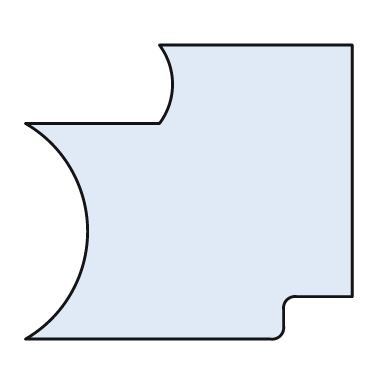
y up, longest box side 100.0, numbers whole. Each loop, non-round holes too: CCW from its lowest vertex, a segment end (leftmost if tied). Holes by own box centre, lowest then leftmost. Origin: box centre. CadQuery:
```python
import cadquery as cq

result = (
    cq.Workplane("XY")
    .moveTo(-50.0, -45.0)
    .lineTo(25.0, -45.0)
    .threePointArc((28.0, -44.0), (29.0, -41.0))
    .lineTo(29.0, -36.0)
    .threePointArc((30.0, -33.0), (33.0, -32.0))
    .lineTo(50.0, -32.0)
    .lineTo(50.0, 45.0)
    .lineTo(-9.0, 45.0)
    .threePointArc((-5.0, 33.0), (-9.0, 21.0))
    .lineTo(-50.0, 21.0)
    .threePointArc((-31.0, -12.0), (-50.0, -45.0))
    .close()
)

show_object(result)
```